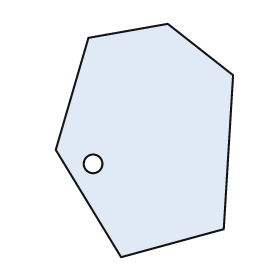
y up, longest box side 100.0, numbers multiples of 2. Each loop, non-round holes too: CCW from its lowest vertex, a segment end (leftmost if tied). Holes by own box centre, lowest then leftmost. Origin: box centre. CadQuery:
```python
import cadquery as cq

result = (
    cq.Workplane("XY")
    .moveTo(-10.0, -50.0)
    .lineTo(34.0, -38.0)
    .lineTo(38.0, 28.0)
    .lineTo(10.0, 50.0)
    .lineTo(-24.0, 44.0)
    .lineTo(-38.0, -4.0)
    .close()
    .moveTo(-22.0, -10.0)
    .circle(4.0)
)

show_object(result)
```